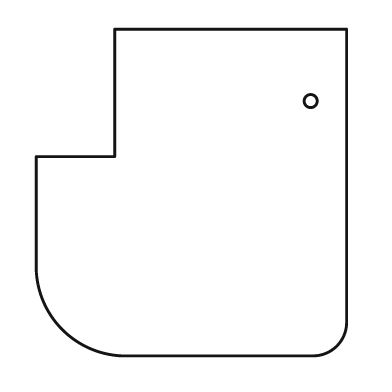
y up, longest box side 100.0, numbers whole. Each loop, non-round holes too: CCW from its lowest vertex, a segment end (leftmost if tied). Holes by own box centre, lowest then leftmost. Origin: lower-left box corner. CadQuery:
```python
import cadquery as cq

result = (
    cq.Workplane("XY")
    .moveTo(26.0, 0.0)
    .lineTo(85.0, 0.0)
    .threePointArc((92.0, 3.0), (95.0, 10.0))
    .lineTo(95.0, 100.0)
    .lineTo(24.0, 100.0)
    .lineTo(24.0, 61.0)
    .lineTo(0.0, 61.0)
    .lineTo(0.0, 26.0)
    .threePointArc((8.0, 8.0), (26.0, 0.0))
    .close()
    .moveTo(84.0, 78.0)
    .circle(2.0)
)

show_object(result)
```